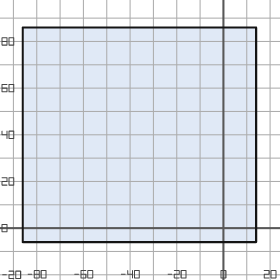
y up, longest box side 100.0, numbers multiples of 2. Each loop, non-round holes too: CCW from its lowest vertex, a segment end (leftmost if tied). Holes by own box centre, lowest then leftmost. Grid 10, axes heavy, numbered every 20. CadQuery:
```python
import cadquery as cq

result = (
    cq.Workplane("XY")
    .moveTo(-86.0, -6.0)
    .lineTo(14.0, -6.0)
    .lineTo(14.0, 86.0)
    .lineTo(-86.0, 86.0)
    .close()
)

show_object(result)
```